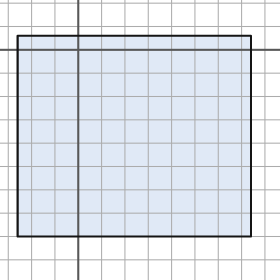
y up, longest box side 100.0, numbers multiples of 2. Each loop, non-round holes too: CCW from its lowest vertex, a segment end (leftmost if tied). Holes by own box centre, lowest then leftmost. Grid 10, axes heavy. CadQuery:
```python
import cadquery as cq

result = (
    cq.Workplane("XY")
    .moveTo(-26.0, -80.0)
    .lineTo(74.0, -80.0)
    .lineTo(74.0, 6.0)
    .lineTo(-26.0, 6.0)
    .close()
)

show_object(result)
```